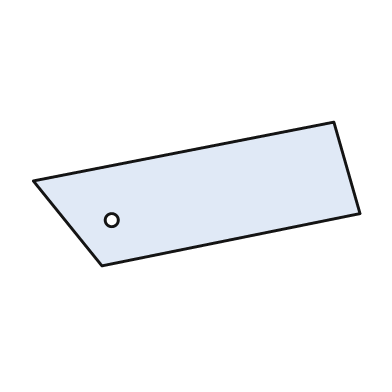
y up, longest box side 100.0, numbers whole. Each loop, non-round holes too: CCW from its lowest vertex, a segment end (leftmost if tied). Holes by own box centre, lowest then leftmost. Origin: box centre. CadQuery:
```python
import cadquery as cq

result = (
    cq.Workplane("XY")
    .moveTo(-29.0, -22.0)
    .lineTo(50.0, -6.0)
    .lineTo(42.0, 22.0)
    .lineTo(-50.0, 4.0)
    .close()
    .moveTo(-26.0, -8.0)
    .circle(2.0)
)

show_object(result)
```